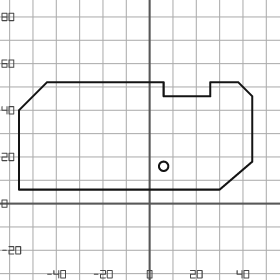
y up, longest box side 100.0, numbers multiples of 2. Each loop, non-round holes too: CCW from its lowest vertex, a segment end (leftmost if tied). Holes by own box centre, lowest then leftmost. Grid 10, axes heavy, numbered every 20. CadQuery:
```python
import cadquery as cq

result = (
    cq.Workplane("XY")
    .moveTo(-56.0, 6.0)
    .lineTo(30.0, 6.0)
    .lineTo(44.0, 18.0)
    .lineTo(44.0, 46.0)
    .lineTo(38.0, 52.0)
    .lineTo(26.0, 52.0)
    .lineTo(26.0, 46.0)
    .lineTo(6.0, 46.0)
    .lineTo(6.0, 52.0)
    .lineTo(-44.0, 52.0)
    .lineTo(-56.0, 40.0)
    .close()
    .moveTo(6.0, 16.0)
    .circle(2.0)
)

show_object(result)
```